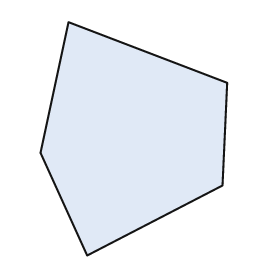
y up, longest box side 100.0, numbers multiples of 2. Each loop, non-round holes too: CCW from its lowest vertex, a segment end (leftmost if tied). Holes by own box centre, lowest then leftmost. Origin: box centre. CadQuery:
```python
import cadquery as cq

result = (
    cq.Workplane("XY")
    .moveTo(-20.0, -50.0)
    .lineTo(38.0, -20.0)
    .lineTo(40.0, 24.0)
    .lineTo(-28.0, 50.0)
    .lineTo(-40.0, -6.0)
    .close()
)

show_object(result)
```